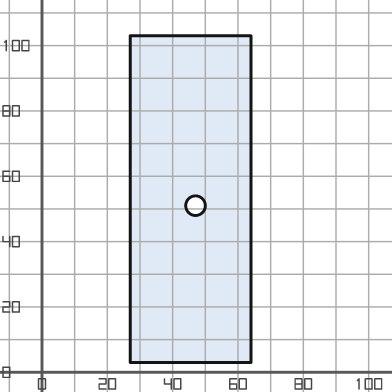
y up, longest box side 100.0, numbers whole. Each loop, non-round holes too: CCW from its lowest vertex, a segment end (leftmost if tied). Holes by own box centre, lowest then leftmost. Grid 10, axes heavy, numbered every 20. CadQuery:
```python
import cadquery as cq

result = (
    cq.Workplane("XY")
    .moveTo(27.0, 3.0)
    .lineTo(64.0, 3.0)
    .lineTo(64.0, 103.0)
    .lineTo(27.0, 103.0)
    .close()
    .moveTo(47.0, 51.0)
    .circle(3.0)
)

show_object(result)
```